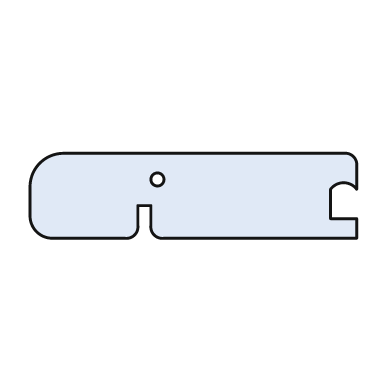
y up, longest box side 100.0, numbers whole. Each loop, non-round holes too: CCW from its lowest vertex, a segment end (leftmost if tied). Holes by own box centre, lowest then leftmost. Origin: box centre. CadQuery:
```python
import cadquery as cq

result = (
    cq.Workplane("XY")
    .moveTo(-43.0, -13.0)
    .lineTo(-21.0, -13.0)
    .threePointArc((-18.0, -12.0), (-17.0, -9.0))
    .lineTo(-17.0, -3.0)
    .lineTo(-13.0, -3.0)
    .lineTo(-13.0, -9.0)
    .threePointArc((-12.0, -12.0), (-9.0, -13.0))
    .lineTo(50.0, -13.0)
    .lineTo(50.0, -7.0)
    .lineTo(42.0, -7.0)
    .lineTo(42.0, 2.0)
    .threePointArc((46.0, 4.0), (50.0, 2.0))
    .lineTo(50.0, 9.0)
    .threePointArc((49.0, 12.0), (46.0, 13.0))
    .lineTo(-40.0, 13.0)
    .threePointArc((-47.0, 10.0), (-50.0, 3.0))
    .lineTo(-50.0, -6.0)
    .threePointArc((-48.0, -11.0), (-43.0, -13.0))
    .close()
    .moveTo(-11.0, 5.0)
    .circle(2.0)
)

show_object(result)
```